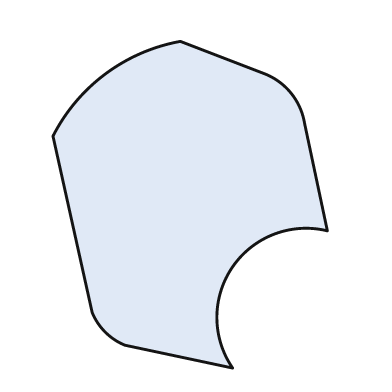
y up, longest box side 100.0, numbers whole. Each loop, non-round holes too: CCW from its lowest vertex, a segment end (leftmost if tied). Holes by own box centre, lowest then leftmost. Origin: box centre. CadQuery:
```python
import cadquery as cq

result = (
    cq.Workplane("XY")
    .moveTo(13.0, -50.0)
    .threePointArc((13.0, -19.0), (42.0, -8.0))
    .lineTo(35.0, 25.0)
    .threePointArc((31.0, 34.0), (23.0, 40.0))
    .lineTo(-3.0, 50.0)
    .threePointArc((-26.0, 40.0), (-42.0, 21.0))
    .lineTo(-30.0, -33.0)
    .threePointArc((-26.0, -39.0), (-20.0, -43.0))
    .close()
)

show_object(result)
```